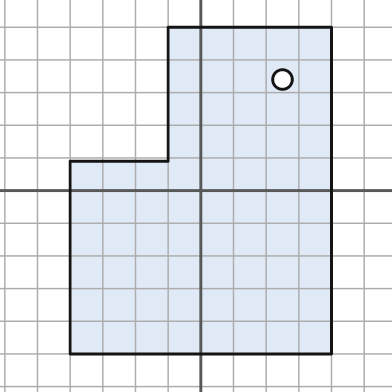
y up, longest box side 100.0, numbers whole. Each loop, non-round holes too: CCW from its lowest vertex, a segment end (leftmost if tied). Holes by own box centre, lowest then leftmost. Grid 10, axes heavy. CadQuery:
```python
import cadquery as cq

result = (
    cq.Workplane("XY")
    .moveTo(-40.0, -50.0)
    .lineTo(40.0, -50.0)
    .lineTo(40.0, 50.0)
    .lineTo(-10.0, 50.0)
    .lineTo(-10.0, 9.0)
    .lineTo(-40.0, 9.0)
    .close()
    .moveTo(25.0, 34.0)
    .circle(3.0)
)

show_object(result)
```